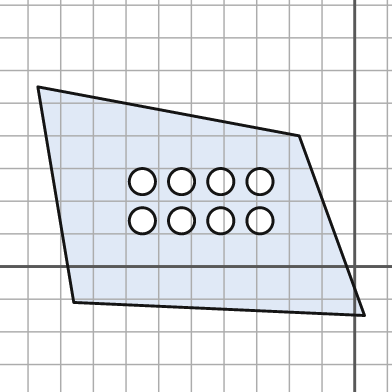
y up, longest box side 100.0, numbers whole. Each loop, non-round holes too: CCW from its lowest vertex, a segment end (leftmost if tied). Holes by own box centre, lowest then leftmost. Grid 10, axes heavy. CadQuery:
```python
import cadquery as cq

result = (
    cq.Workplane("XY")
    .moveTo(3.0, -15.0)
    .lineTo(-17.0, 40.0)
    .lineTo(-97.0, 55.0)
    .lineTo(-86.0, -11.0)
    .close()
    .moveTo(-65.0, 14.0)
    .circle(4.0)
    .moveTo(-53.0, 14.0)
    .circle(4.0)
    .moveTo(-41.0, 14.0)
    .circle(4.0)
    .moveTo(-29.0, 14.0)
    .circle(4.0)
    .moveTo(-65.0, 26.0)
    .circle(4.0)
    .moveTo(-53.0, 26.0)
    .circle(4.0)
    .moveTo(-41.0, 26.0)
    .circle(4.0)
    .moveTo(-29.0, 26.0)
    .circle(4.0)
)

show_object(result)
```